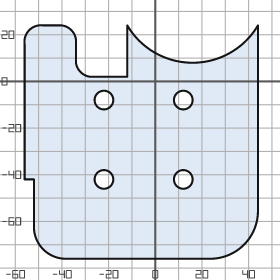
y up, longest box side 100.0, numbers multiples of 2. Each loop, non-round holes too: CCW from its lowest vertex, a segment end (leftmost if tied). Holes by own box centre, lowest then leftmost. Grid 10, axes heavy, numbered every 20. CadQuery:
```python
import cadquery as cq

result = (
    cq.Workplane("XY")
    .moveTo(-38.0, -76.0)
    .lineTo(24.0, -76.0)
    .threePointArc((38.0, -70.0), (44.0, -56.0))
    .lineTo(44.0, 24.0)
    .threePointArc((16.0, 8.0), (-12.0, 24.0))
    .lineTo(-12.0, 2.0)
    .lineTo(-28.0, 2.0)
    .threePointArc((-32.0, 4.0), (-34.0, 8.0))
    .lineTo(-34.0, 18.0)
    .threePointArc((-36.0, 22.0), (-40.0, 24.0))
    .lineTo(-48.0, 24.0)
    .threePointArc((-54.0, 22.0), (-56.0, 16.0))
    .lineTo(-56.0, -42.0)
    .lineTo(-52.0, -42.0)
    .lineTo(-52.0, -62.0)
    .threePointArc((-48.0, -72.0), (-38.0, -76.0))
    .close()
    .moveTo(-22.0, -42.0)
    .circle(4.0)
    .moveTo(12.0, -42.0)
    .circle(4.0)
    .moveTo(-22.0, -8.0)
    .circle(4.0)
    .moveTo(12.0, -8.0)
    .circle(4.0)
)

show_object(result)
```